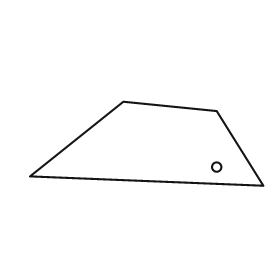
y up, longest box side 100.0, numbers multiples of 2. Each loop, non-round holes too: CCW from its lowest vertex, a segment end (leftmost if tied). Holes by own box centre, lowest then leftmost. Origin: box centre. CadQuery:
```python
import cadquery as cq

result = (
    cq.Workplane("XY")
    .moveTo(50.0, -18.0)
    .lineTo(30.0, 14.0)
    .lineTo(-10.0, 18.0)
    .lineTo(-50.0, -14.0)
    .close()
    .moveTo(30.0, -10.0)
    .circle(2.0)
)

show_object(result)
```